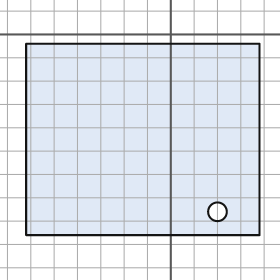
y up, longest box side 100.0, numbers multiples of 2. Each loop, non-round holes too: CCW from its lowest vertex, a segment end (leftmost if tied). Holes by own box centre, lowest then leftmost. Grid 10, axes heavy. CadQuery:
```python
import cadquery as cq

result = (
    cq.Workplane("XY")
    .moveTo(-62.0, -86.0)
    .lineTo(38.0, -86.0)
    .lineTo(38.0, -4.0)
    .lineTo(-62.0, -4.0)
    .close()
    .moveTo(20.0, -76.0)
    .circle(4.0)
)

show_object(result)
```